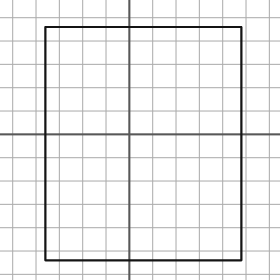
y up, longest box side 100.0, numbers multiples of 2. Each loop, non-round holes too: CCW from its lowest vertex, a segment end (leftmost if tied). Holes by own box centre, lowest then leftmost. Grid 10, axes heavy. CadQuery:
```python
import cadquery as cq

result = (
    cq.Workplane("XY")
    .moveTo(-36.0, -54.0)
    .lineTo(48.0, -54.0)
    .lineTo(48.0, 46.0)
    .lineTo(-36.0, 46.0)
    .close()
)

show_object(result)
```